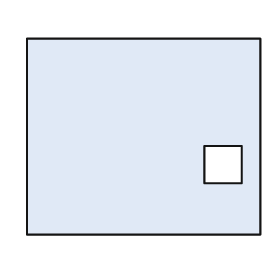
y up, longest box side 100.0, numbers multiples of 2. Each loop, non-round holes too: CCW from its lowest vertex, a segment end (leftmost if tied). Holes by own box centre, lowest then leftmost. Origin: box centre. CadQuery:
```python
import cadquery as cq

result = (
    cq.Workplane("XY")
    .moveTo(-50.0, -42.0)
    .lineTo(50.0, -42.0)
    .lineTo(50.0, 42.0)
    .lineTo(-50.0, 42.0)
    .close()
    .moveTo(26.0, -20.0)
    .lineTo(42.0, -20.0)
    .lineTo(42.0, -4.0)
    .lineTo(26.0, -4.0)
    .close()
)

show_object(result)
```